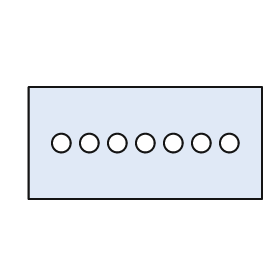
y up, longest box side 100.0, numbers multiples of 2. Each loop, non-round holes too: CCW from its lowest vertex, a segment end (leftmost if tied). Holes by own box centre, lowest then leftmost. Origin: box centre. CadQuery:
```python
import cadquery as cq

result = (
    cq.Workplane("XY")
    .moveTo(-50.0, -24.0)
    .lineTo(50.0, -24.0)
    .lineTo(50.0, 24.0)
    .lineTo(-50.0, 24.0)
    .close()
    .moveTo(-36.0, 0.0)
    .circle(4.0)
    .moveTo(-24.0, 0.0)
    .circle(4.0)
    .moveTo(-12.0, 0.0)
    .circle(4.0)
    .moveTo(0.0, 0.0)
    .circle(4.0)
    .moveTo(12.0, 0.0)
    .circle(4.0)
    .moveTo(24.0, 0.0)
    .circle(4.0)
    .moveTo(36.0, 0.0)
    .circle(4.0)
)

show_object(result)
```